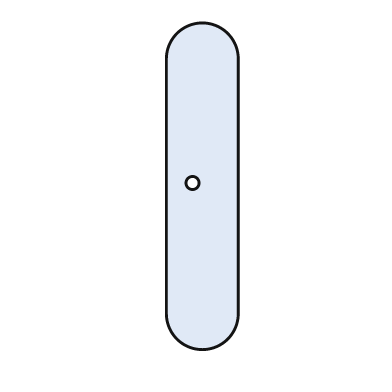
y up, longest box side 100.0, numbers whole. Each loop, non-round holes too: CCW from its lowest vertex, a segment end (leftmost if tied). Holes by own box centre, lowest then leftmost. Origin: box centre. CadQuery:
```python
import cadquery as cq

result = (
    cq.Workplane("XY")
    .moveTo(-11.0, -39.0)
    .threePointArc((0.0, -50.0), (11.0, -39.0))
    .lineTo(11.0, 39.0)
    .threePointArc((0.0, 50.0), (-11.0, 39.0))
    .close()
    .moveTo(-3.0, 1.0)
    .circle(2.0)
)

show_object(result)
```